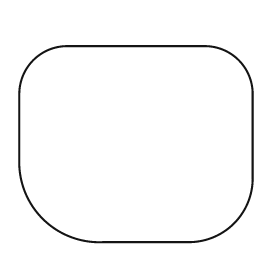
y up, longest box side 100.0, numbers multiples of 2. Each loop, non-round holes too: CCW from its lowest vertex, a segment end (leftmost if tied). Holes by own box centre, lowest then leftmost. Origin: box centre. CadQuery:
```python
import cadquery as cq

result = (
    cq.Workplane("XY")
    .moveTo(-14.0, -42.0)
    .lineTo(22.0, -42.0)
    .threePointArc((42.0, -34.0), (50.0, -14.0))
    .lineTo(50.0, 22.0)
    .threePointArc((44.0, 36.0), (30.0, 42.0))
    .lineTo(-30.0, 42.0)
    .threePointArc((-44.0, 36.0), (-50.0, 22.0))
    .lineTo(-50.0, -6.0)
    .threePointArc((-40.0, -32.0), (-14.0, -42.0))
    .close()
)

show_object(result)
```